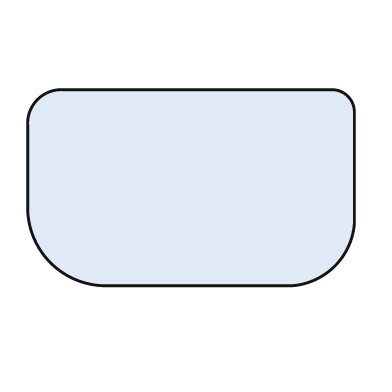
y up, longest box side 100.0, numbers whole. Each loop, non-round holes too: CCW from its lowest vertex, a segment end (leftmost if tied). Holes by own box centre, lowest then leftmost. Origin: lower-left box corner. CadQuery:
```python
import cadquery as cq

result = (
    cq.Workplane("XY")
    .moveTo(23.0, 0.0)
    .lineTo(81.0, 0.0)
    .threePointArc((94.0, 6.0), (100.0, 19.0))
    .lineTo(100.0, 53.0)
    .threePointArc((98.0, 58.0), (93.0, 60.0))
    .lineTo(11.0, 60.0)
    .threePointArc((3.0, 57.0), (0.0, 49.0))
    .lineTo(0.0, 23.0)
    .threePointArc((7.0, 7.0), (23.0, 0.0))
    .close()
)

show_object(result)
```